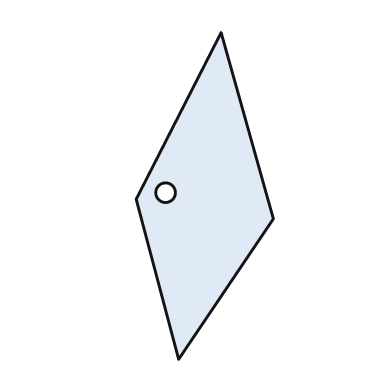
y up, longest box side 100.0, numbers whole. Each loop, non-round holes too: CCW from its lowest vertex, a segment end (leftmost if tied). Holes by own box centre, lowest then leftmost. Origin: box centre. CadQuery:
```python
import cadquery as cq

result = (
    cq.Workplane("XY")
    .moveTo(-8.0, -50.0)
    .lineTo(21.0, -7.0)
    .lineTo(5.0, 50.0)
    .lineTo(-21.0, -1.0)
    .close()
    .moveTo(-12.0, 1.0)
    .circle(3.0)
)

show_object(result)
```